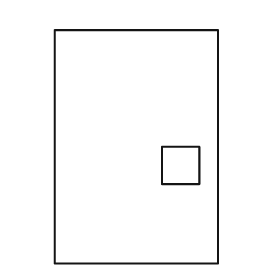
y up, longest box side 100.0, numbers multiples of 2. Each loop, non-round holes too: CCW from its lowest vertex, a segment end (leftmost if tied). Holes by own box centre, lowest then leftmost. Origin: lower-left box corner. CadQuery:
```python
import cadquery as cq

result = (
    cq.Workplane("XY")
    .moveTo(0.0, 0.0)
    .lineTo(70.0, 0.0)
    .lineTo(70.0, 100.0)
    .lineTo(0.0, 100.0)
    .close()
    .moveTo(46.0, 34.0)
    .lineTo(62.0, 34.0)
    .lineTo(62.0, 50.0)
    .lineTo(46.0, 50.0)
    .close()
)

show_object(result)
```